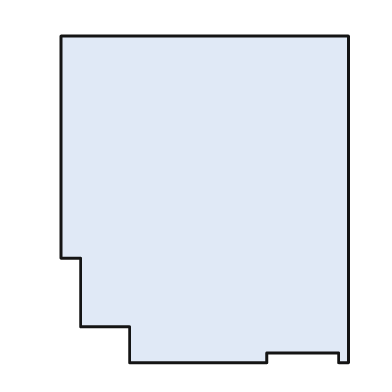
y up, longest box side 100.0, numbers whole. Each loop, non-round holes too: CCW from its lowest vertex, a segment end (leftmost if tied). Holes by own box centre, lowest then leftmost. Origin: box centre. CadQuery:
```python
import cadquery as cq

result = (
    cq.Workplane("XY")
    .moveTo(-23.0, -50.0)
    .lineTo(19.0, -50.0)
    .lineTo(19.0, -47.0)
    .lineTo(41.0, -47.0)
    .lineTo(41.0, -50.0)
    .lineTo(44.0, -50.0)
    .lineTo(44.0, 50.0)
    .lineTo(-44.0, 50.0)
    .lineTo(-44.0, -18.0)
    .lineTo(-38.0, -18.0)
    .lineTo(-38.0, -39.0)
    .lineTo(-23.0, -39.0)
    .close()
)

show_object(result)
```